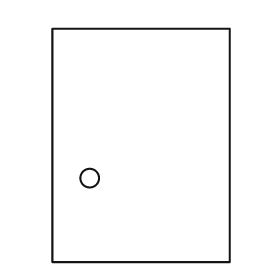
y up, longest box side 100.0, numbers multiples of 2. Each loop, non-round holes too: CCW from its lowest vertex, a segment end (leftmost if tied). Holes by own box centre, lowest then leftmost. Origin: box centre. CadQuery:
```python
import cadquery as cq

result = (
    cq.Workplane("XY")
    .moveTo(-38.0, -50.0)
    .lineTo(38.0, -50.0)
    .lineTo(38.0, 50.0)
    .lineTo(-38.0, 50.0)
    .close()
    .moveTo(-22.0, -14.0)
    .circle(4.0)
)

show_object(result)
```